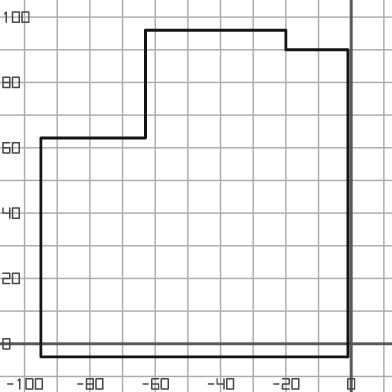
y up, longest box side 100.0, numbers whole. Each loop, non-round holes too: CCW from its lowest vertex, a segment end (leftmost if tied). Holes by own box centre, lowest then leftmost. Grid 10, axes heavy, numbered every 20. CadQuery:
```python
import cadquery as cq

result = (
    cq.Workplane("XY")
    .moveTo(-95.0, -4.0)
    .lineTo(-1.0, -4.0)
    .lineTo(-1.0, 90.0)
    .lineTo(-20.0, 90.0)
    .lineTo(-20.0, 96.0)
    .lineTo(-63.0, 96.0)
    .lineTo(-63.0, 63.0)
    .lineTo(-95.0, 63.0)
    .close()
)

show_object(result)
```